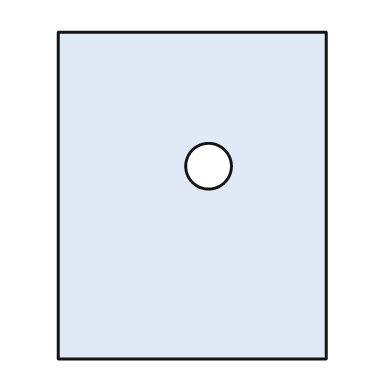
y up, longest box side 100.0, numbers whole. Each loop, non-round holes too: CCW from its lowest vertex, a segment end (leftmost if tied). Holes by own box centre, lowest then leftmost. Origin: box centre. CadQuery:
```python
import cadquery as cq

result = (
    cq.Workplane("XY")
    .moveTo(-41.0, -50.0)
    .lineTo(41.0, -50.0)
    .lineTo(41.0, 50.0)
    .lineTo(-41.0, 50.0)
    .close()
    .moveTo(5.0, 9.0)
    .circle(7.0)
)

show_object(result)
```